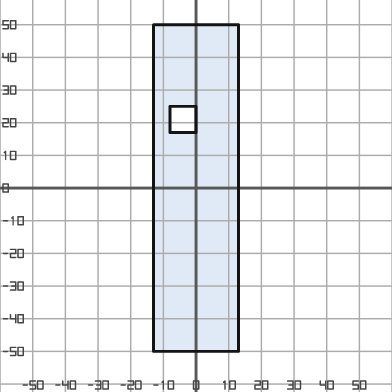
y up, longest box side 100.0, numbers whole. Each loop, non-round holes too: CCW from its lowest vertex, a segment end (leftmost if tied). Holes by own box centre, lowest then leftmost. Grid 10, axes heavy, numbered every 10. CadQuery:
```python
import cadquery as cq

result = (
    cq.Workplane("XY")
    .moveTo(-13.0, -50.0)
    .lineTo(13.0, -50.0)
    .lineTo(13.0, 50.0)
    .lineTo(-13.0, 50.0)
    .close()
    .moveTo(-8.0, 17.0)
    .lineTo(0.0, 17.0)
    .lineTo(0.0, 25.0)
    .lineTo(-8.0, 25.0)
    .close()
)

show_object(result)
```